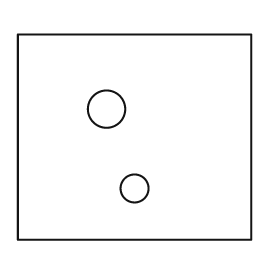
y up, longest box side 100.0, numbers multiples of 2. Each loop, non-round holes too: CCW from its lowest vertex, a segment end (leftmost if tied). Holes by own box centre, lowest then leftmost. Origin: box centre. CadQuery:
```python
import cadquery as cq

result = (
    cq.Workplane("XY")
    .moveTo(-50.0, -44.0)
    .lineTo(50.0, -44.0)
    .lineTo(50.0, 44.0)
    .lineTo(-50.0, 44.0)
    .close()
    .moveTo(0.0, -22.0)
    .circle(6.0)
    .moveTo(-12.0, 12.0)
    .circle(8.0)
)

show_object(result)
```